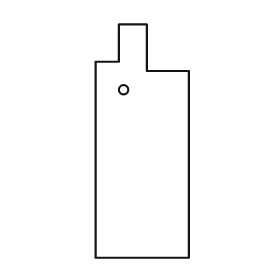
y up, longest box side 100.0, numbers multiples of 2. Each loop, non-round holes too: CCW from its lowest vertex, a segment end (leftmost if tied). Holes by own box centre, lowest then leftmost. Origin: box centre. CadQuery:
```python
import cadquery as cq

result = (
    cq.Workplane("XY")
    .moveTo(-20.0, -50.0)
    .lineTo(20.0, -50.0)
    .lineTo(20.0, 30.0)
    .lineTo(2.0, 30.0)
    .lineTo(2.0, 50.0)
    .lineTo(-10.0, 50.0)
    .lineTo(-10.0, 34.0)
    .lineTo(-20.0, 34.0)
    .close()
    .moveTo(-8.0, 22.0)
    .circle(2.0)
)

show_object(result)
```